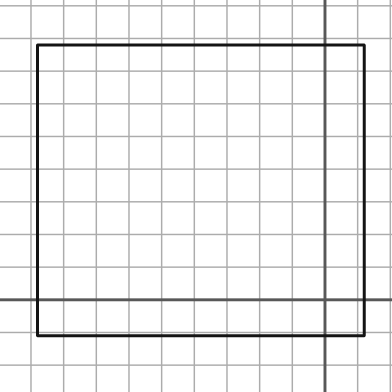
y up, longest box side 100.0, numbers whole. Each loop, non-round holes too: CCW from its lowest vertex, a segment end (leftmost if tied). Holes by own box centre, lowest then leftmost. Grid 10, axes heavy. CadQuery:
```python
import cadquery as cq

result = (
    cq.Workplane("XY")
    .moveTo(-88.0, -11.0)
    .lineTo(12.0, -11.0)
    .lineTo(12.0, 78.0)
    .lineTo(-88.0, 78.0)
    .close()
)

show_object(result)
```